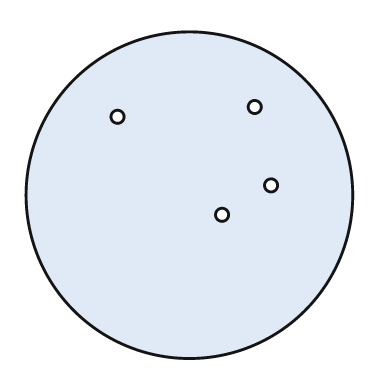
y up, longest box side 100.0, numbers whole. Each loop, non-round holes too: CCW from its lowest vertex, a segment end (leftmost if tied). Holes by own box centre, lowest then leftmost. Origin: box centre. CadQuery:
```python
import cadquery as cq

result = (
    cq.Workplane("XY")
    .moveTo(0.0, 0.0)
    .circle(50.0)
    .moveTo(10.0, -6.0)
    .circle(2.0)
    .moveTo(25.0, 3.0)
    .circle(2.0)
    .moveTo(-22.0, 24.0)
    .circle(2.0)
    .moveTo(20.0, 27.0)
    .circle(2.0)
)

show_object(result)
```